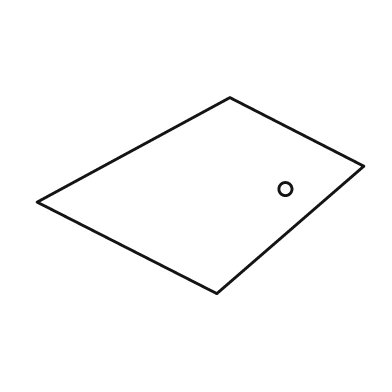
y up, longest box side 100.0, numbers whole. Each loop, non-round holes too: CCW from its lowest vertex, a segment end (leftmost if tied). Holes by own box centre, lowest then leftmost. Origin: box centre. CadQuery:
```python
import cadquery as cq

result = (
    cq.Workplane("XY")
    .moveTo(5.0, -30.0)
    .lineTo(50.0, 9.0)
    .lineTo(9.0, 30.0)
    .lineTo(-50.0, -2.0)
    .close()
    .moveTo(26.0, 2.0)
    .circle(2.0)
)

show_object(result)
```